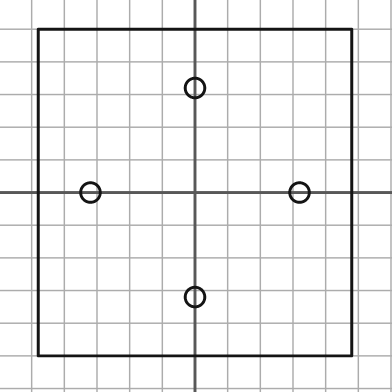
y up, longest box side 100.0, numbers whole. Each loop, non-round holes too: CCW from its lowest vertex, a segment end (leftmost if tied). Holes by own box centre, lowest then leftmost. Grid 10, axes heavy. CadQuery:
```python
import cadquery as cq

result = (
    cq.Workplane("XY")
    .moveTo(-48.0, -50.0)
    .lineTo(48.0, -50.0)
    .lineTo(48.0, 50.0)
    .lineTo(-48.0, 50.0)
    .close()
    .moveTo(0.0, -32.0)
    .circle(3.0)
    .moveTo(-32.0, 0.0)
    .circle(3.0)
    .moveTo(32.0, 0.0)
    .circle(3.0)
    .moveTo(0.0, 32.0)
    .circle(3.0)
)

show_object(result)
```